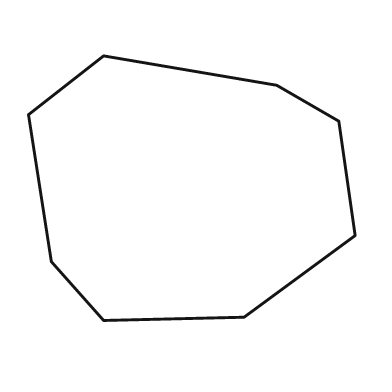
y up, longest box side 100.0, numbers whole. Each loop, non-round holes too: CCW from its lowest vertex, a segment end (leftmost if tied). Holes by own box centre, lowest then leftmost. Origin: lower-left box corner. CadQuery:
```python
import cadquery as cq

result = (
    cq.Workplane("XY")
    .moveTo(23.0, 0.0)
    .lineTo(66.0, 1.0)
    .lineTo(100.0, 26.0)
    .lineTo(95.0, 61.0)
    .lineTo(76.0, 72.0)
    .lineTo(23.0, 81.0)
    .lineTo(0.0, 63.0)
    .lineTo(7.0, 18.0)
    .close()
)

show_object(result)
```